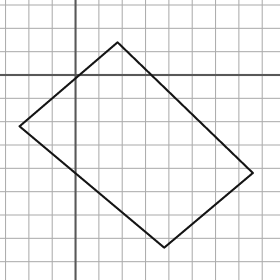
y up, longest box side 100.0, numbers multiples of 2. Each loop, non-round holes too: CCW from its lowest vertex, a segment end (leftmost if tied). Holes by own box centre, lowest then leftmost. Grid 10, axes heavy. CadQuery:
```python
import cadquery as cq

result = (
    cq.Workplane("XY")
    .moveTo(38.0, -74.0)
    .lineTo(76.0, -42.0)
    .lineTo(18.0, 14.0)
    .lineTo(-24.0, -22.0)
    .close()
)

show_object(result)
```